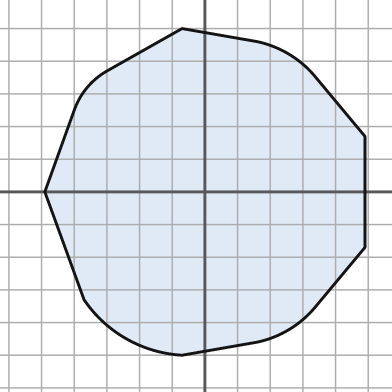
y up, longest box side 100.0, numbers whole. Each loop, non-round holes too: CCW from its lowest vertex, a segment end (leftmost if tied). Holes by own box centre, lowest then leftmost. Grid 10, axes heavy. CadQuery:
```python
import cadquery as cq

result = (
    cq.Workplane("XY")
    .moveTo(-7.0, -50.0)
    .lineTo(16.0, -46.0)
    .threePointArc((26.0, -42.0), (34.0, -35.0))
    .lineTo(49.0, -17.0)
    .lineTo(49.0, 17.0)
    .lineTo(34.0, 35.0)
    .threePointArc((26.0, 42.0), (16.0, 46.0))
    .lineTo(-7.0, 50.0)
    .lineTo(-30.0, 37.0)
    .threePointArc((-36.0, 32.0), (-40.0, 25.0))
    .lineTo(-49.0, 0.0)
    .lineTo(-37.0, -33.0)
    .threePointArc((-24.0, -45.0), (-7.0, -50.0))
    .close()
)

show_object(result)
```